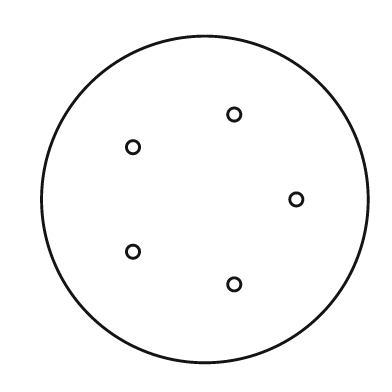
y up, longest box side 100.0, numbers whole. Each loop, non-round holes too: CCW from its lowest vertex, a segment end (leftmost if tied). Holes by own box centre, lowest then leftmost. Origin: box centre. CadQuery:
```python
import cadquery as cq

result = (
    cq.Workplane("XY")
    .moveTo(0.0, 0.0)
    .circle(50.0)
    .moveTo(9.0, -26.0)
    .circle(2.0)
    .moveTo(-22.0, -16.0)
    .circle(2.0)
    .moveTo(28.0, 0.0)
    .circle(2.0)
    .moveTo(-22.0, 16.0)
    .circle(2.0)
    .moveTo(9.0, 26.0)
    .circle(2.0)
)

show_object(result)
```